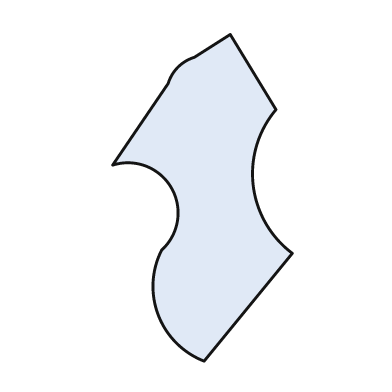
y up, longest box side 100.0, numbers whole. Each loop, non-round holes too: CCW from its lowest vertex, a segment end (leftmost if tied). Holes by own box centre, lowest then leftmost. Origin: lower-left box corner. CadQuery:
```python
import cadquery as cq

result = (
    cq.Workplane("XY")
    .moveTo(28.0, 0.0)
    .lineTo(55.0, 33.0)
    .threePointArc((43.0, 54.0), (50.0, 77.0))
    .lineTo(36.0, 100.0)
    .lineTo(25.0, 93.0)
    .threePointArc((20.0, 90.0), (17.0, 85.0))
    .lineTo(0.0, 60.0)
    .threePointArc((18.0, 53.0), (15.0, 34.0))
    .threePointArc((14.0, 14.0), (28.0, 0.0))
    .close()
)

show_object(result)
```